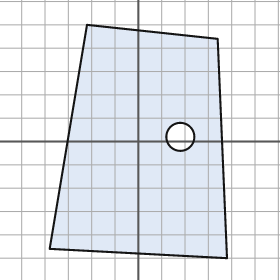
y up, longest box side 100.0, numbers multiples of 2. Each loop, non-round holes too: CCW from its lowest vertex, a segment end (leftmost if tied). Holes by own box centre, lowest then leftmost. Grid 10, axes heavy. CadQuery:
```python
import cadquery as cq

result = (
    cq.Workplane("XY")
    .moveTo(38.0, -50.0)
    .lineTo(34.0, 44.0)
    .lineTo(-22.0, 50.0)
    .lineTo(-38.0, -46.0)
    .close()
    .moveTo(18.0, 2.0)
    .circle(6.0)
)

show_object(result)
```